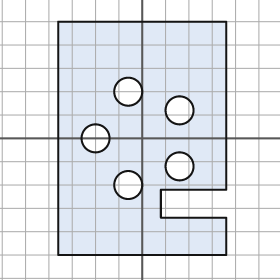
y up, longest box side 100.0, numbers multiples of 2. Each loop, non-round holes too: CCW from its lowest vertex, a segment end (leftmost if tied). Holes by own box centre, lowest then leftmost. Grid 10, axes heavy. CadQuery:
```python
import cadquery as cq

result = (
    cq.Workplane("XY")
    .moveTo(-36.0, -50.0)
    .lineTo(36.0, -50.0)
    .lineTo(36.0, -34.0)
    .lineTo(8.0, -34.0)
    .lineTo(8.0, -22.0)
    .lineTo(36.0, -22.0)
    .lineTo(36.0, 50.0)
    .lineTo(-36.0, 50.0)
    .close()
    .moveTo(-6.0, -20.0)
    .circle(6.0)
    .moveTo(16.0, -12.0)
    .circle(6.0)
    .moveTo(-20.0, 0.0)
    .circle(6.0)
    .moveTo(16.0, 12.0)
    .circle(6.0)
    .moveTo(-6.0, 20.0)
    .circle(6.0)
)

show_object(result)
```